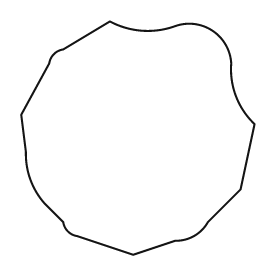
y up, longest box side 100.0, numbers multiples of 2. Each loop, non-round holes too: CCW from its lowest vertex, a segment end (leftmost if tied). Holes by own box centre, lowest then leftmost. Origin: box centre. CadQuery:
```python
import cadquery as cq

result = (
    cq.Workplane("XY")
    .moveTo(-2.0, -50.0)
    .lineTo(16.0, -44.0)
    .threePointArc((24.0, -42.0), (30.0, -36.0))
    .lineTo(44.0, -22.0)
    .lineTo(50.0, 6.0)
    .threePointArc((42.0, 18.0), (40.0, 32.0))
    .threePointArc((32.0, 46.0), (16.0, 48.0))
    .threePointArc((2.0, 46.0), (-12.0, 50.0))
    .lineTo(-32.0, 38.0)
    .threePointArc((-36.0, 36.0), (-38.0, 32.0))
    .lineTo(-50.0, 10.0)
    .lineTo(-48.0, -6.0)
    .threePointArc((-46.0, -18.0), (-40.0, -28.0))
    .lineTo(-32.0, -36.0)
    .threePointArc((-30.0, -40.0), (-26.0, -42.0))
    .close()
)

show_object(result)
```